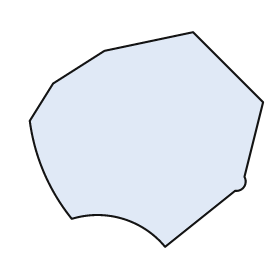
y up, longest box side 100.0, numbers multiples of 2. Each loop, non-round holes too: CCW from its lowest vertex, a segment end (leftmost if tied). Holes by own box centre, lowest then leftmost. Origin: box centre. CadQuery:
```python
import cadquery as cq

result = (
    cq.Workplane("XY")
    .moveTo(8.0, -46.0)
    .lineTo(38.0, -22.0)
    .threePointArc((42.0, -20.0), (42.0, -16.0))
    .lineTo(50.0, 16.0)
    .lineTo(20.0, 46.0)
    .lineTo(-18.0, 38.0)
    .lineTo(-40.0, 24.0)
    .lineTo(-50.0, 8.0)
    .threePointArc((-44.0, -14.0), (-32.0, -34.0))
    .threePointArc((-10.0, -34.0), (8.0, -46.0))
    .close()
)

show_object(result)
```